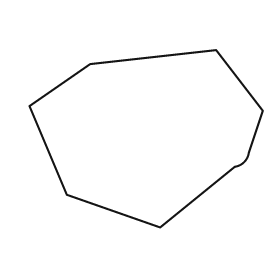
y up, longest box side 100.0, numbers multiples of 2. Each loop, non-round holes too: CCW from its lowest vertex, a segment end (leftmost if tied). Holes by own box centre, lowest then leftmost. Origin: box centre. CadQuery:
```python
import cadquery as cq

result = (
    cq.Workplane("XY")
    .moveTo(6.0, -38.0)
    .lineTo(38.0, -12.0)
    .threePointArc((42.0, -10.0), (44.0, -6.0))
    .lineTo(50.0, 12.0)
    .lineTo(30.0, 38.0)
    .lineTo(-24.0, 32.0)
    .lineTo(-50.0, 14.0)
    .lineTo(-34.0, -24.0)
    .close()
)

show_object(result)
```